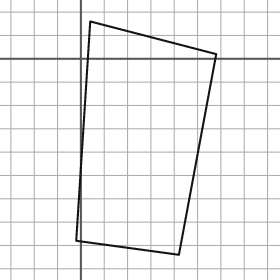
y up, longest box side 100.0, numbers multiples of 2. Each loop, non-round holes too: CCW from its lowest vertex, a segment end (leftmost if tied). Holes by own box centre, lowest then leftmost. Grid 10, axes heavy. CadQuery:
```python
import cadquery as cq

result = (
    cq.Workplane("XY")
    .moveTo(42.0, -84.0)
    .lineTo(58.0, 2.0)
    .lineTo(4.0, 16.0)
    .lineTo(-2.0, -78.0)
    .close()
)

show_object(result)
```